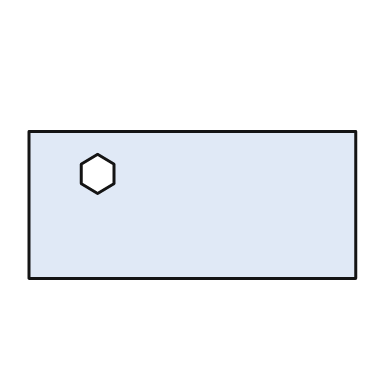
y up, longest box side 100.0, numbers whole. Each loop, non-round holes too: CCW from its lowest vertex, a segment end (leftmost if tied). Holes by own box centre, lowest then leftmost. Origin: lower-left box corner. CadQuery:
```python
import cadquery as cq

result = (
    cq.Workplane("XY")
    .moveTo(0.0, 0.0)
    .lineTo(100.0, 0.0)
    .lineTo(100.0, 45.0)
    .lineTo(0.0, 45.0)
    .close()
    .moveTo(21.0, 26.0)
    .lineTo(26.0, 29.0)
    .lineTo(26.0, 35.0)
    .lineTo(21.0, 38.0)
    .lineTo(16.0, 35.0)
    .lineTo(16.0, 29.0)
    .close()
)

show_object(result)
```